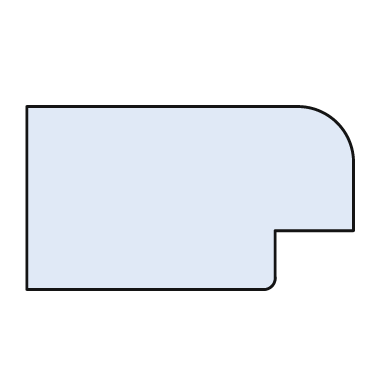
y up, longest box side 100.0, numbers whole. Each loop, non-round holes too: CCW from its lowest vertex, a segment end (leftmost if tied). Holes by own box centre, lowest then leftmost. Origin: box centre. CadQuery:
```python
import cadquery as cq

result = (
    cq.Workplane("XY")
    .moveTo(-50.0, -28.0)
    .lineTo(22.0, -28.0)
    .threePointArc((25.0, -27.0), (26.0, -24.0))
    .lineTo(26.0, -10.0)
    .lineTo(50.0, -10.0)
    .lineTo(50.0, 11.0)
    .threePointArc((45.0, 23.0), (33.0, 28.0))
    .lineTo(-50.0, 28.0)
    .close()
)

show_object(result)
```